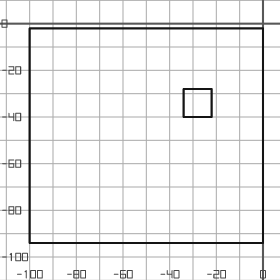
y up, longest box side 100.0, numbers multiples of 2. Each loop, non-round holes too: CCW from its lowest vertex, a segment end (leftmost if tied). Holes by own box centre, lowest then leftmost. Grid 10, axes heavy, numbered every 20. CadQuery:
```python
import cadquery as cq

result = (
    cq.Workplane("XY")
    .moveTo(-100.0, -94.0)
    .lineTo(0.0, -94.0)
    .lineTo(0.0, -2.0)
    .lineTo(-100.0, -2.0)
    .close()
    .moveTo(-34.0, -40.0)
    .lineTo(-22.0, -40.0)
    .lineTo(-22.0, -28.0)
    .lineTo(-34.0, -28.0)
    .close()
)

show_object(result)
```